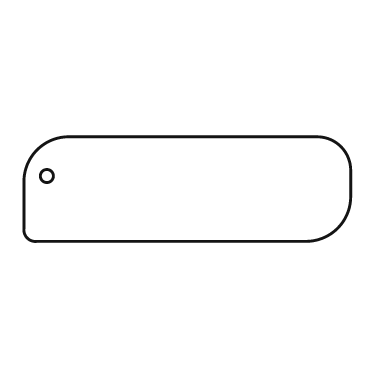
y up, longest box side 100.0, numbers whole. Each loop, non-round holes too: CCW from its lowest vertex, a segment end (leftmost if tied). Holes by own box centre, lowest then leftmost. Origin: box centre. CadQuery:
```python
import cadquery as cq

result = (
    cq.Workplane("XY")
    .moveTo(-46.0, -16.0)
    .lineTo(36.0, -16.0)
    .threePointArc((46.0, -12.0), (50.0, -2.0))
    .lineTo(50.0, 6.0)
    .threePointArc((47.0, 13.0), (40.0, 16.0))
    .lineTo(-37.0, 16.0)
    .threePointArc((-46.0, 12.0), (-50.0, 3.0))
    .lineTo(-50.0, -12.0)
    .threePointArc((-49.0, -15.0), (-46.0, -16.0))
    .close()
    .moveTo(-43.0, 4.0)
    .circle(2.0)
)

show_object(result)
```